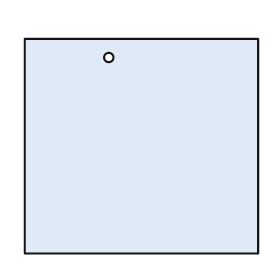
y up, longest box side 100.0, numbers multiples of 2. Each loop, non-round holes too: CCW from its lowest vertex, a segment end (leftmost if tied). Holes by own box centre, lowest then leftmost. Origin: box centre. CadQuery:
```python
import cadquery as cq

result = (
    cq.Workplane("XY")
    .moveTo(-50.0, -46.0)
    .lineTo(50.0, -46.0)
    .lineTo(50.0, 46.0)
    .lineTo(-50.0, 46.0)
    .close()
    .moveTo(-14.0, 38.0)
    .circle(2.0)
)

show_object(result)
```